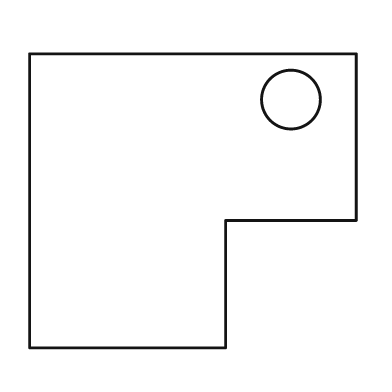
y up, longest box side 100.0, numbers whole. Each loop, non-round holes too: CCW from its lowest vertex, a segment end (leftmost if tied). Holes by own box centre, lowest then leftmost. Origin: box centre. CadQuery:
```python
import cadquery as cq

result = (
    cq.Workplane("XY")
    .moveTo(-50.0, -45.0)
    .lineTo(10.0, -45.0)
    .lineTo(10.0, -6.0)
    .lineTo(50.0, -6.0)
    .lineTo(50.0, 45.0)
    .lineTo(-50.0, 45.0)
    .close()
    .moveTo(30.0, 31.0)
    .circle(9.0)
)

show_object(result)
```